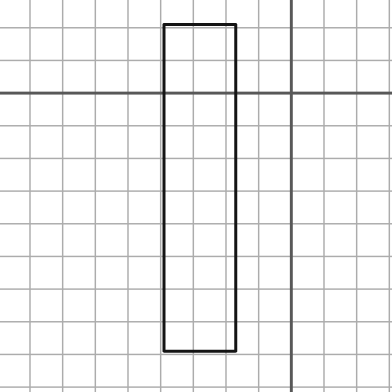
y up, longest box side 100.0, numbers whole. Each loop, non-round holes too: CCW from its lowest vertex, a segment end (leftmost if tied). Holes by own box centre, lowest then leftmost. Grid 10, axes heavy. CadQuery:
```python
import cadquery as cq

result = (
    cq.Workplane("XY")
    .moveTo(-39.0, -79.0)
    .lineTo(-17.0, -79.0)
    .lineTo(-17.0, 21.0)
    .lineTo(-39.0, 21.0)
    .close()
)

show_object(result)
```